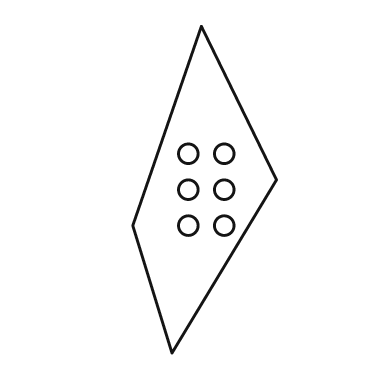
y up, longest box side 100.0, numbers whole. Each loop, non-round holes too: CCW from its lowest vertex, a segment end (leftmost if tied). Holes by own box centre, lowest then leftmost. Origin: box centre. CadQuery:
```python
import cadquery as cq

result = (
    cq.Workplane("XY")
    .moveTo(-10.0, -50.0)
    .lineTo(22.0, 3.0)
    .lineTo(-1.0, 50.0)
    .lineTo(-22.0, -11.0)
    .close()
    .moveTo(-5.0, -11.0)
    .circle(3.0)
    .moveTo(6.0, -11.0)
    .circle(3.0)
    .moveTo(-5.0, 0.0)
    .circle(3.0)
    .moveTo(6.0, 0.0)
    .circle(3.0)
    .moveTo(-5.0, 11.0)
    .circle(3.0)
    .moveTo(6.0, 11.0)
    .circle(3.0)
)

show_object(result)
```